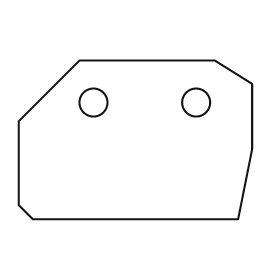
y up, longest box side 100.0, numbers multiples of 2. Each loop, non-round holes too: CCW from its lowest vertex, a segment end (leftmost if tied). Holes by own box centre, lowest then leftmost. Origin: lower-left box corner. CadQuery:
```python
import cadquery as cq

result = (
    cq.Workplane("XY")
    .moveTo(6.0, 0.0)
    .lineTo(94.0, 0.0)
    .lineTo(100.0, 30.0)
    .lineTo(100.0, 58.0)
    .lineTo(84.0, 68.0)
    .lineTo(26.0, 68.0)
    .lineTo(0.0, 42.0)
    .lineTo(0.0, 6.0)
    .close()
    .moveTo(32.0, 50.0)
    .circle(6.0)
    .moveTo(76.0, 50.0)
    .circle(6.0)
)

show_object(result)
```